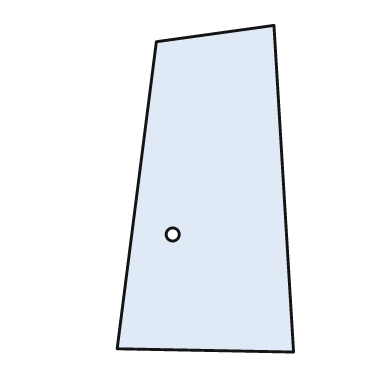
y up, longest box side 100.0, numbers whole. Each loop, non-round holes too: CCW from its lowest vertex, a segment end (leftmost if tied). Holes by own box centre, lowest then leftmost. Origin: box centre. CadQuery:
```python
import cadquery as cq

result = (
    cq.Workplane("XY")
    .moveTo(27.0, -50.0)
    .lineTo(21.0, 50.0)
    .lineTo(-15.0, 45.0)
    .lineTo(-27.0, -49.0)
    .close()
    .moveTo(-10.0, -14.0)
    .circle(2.0)
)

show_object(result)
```